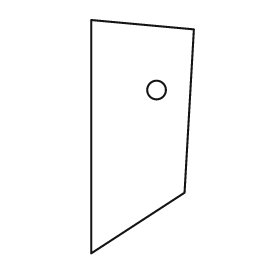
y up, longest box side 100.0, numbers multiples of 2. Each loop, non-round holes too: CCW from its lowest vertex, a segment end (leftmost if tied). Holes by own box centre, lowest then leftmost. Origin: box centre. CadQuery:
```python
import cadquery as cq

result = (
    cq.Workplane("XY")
    .moveTo(-22.0, -50.0)
    .lineTo(18.0, -24.0)
    .lineTo(22.0, 46.0)
    .lineTo(-22.0, 50.0)
    .close()
    .moveTo(6.0, 20.0)
    .circle(4.0)
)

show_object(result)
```